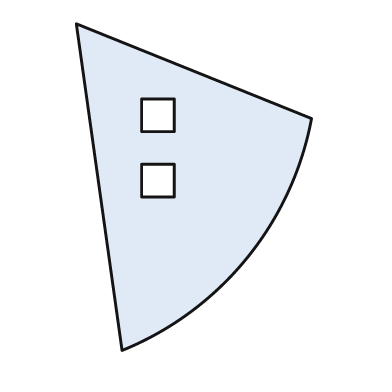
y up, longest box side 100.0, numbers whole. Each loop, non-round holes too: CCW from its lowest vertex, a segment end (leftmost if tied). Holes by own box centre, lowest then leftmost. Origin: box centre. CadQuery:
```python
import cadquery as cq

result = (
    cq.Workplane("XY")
    .moveTo(-22.0, -50.0)
    .threePointArc((16.0, -22.0), (36.0, 21.0))
    .lineTo(-36.0, 50.0)
    .close()
    .moveTo(-16.0, -3.0)
    .lineTo(-6.0, -3.0)
    .lineTo(-6.0, 7.0)
    .lineTo(-16.0, 7.0)
    .close()
    .moveTo(-16.0, 17.0)
    .lineTo(-6.0, 17.0)
    .lineTo(-6.0, 27.0)
    .lineTo(-16.0, 27.0)
    .close()
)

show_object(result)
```